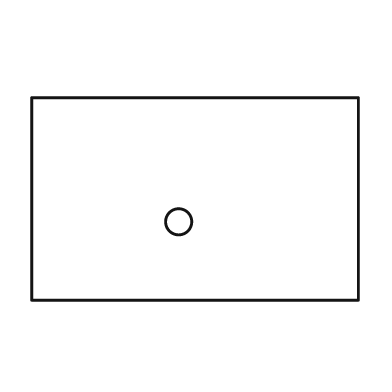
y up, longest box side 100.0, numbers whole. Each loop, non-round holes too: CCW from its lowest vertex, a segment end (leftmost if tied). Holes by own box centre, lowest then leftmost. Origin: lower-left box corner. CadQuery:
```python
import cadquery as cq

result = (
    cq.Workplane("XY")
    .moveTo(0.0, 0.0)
    .lineTo(100.0, 0.0)
    .lineTo(100.0, 62.0)
    .lineTo(0.0, 62.0)
    .close()
    .moveTo(45.0, 24.0)
    .circle(4.0)
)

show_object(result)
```